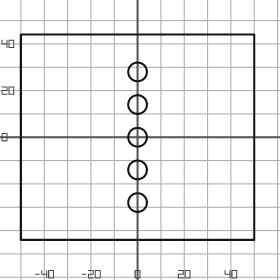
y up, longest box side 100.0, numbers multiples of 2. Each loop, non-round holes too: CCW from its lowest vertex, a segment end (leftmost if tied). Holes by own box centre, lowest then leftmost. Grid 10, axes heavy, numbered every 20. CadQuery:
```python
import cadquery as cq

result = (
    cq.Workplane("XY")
    .moveTo(-50.0, -44.0)
    .lineTo(50.0, -44.0)
    .lineTo(50.0, 44.0)
    .lineTo(-50.0, 44.0)
    .close()
    .moveTo(0.0, -28.0)
    .circle(4.0)
    .moveTo(0.0, -14.0)
    .circle(4.0)
    .moveTo(0.0, 0.0)
    .circle(4.0)
    .moveTo(0.0, 14.0)
    .circle(4.0)
    .moveTo(0.0, 28.0)
    .circle(4.0)
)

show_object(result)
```